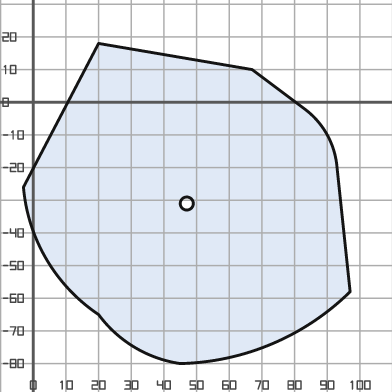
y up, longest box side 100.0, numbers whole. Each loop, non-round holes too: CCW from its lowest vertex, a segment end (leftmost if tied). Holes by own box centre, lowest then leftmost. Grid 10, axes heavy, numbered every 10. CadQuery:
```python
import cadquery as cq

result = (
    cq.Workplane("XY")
    .moveTo(45.0, -80.0)
    .threePointArc((73.0, -74.0), (97.0, -58.0))
    .lineTo(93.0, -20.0)
    .threePointArc((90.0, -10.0), (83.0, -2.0))
    .lineTo(67.0, 10.0)
    .lineTo(20.0, 18.0)
    .lineTo(-3.0, -26.0)
    .threePointArc((4.0, -48.0), (20.0, -65.0))
    .threePointArc((31.0, -75.0), (45.0, -80.0))
    .close()
    .moveTo(47.0, -31.0)
    .circle(2.0)
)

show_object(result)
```